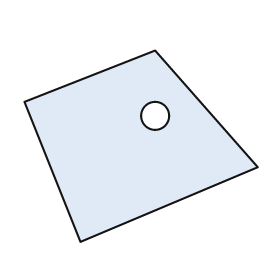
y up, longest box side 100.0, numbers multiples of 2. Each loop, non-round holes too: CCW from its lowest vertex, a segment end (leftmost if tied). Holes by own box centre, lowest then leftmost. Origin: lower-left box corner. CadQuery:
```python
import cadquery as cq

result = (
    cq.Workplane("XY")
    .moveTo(24.0, 0.0)
    .lineTo(100.0, 32.0)
    .lineTo(56.0, 82.0)
    .lineTo(0.0, 60.0)
    .close()
    .moveTo(56.0, 54.0)
    .circle(6.0)
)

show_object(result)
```